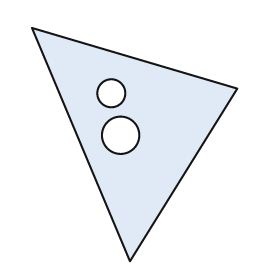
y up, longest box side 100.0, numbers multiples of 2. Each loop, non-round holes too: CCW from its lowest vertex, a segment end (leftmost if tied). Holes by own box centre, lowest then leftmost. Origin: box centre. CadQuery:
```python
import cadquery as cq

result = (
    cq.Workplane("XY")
    .moveTo(-2.0, -50.0)
    .lineTo(44.0, 24.0)
    .lineTo(-44.0, 50.0)
    .close()
    .moveTo(-6.0, 4.0)
    .circle(8.0)
    .moveTo(-10.0, 22.0)
    .circle(6.0)
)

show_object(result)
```